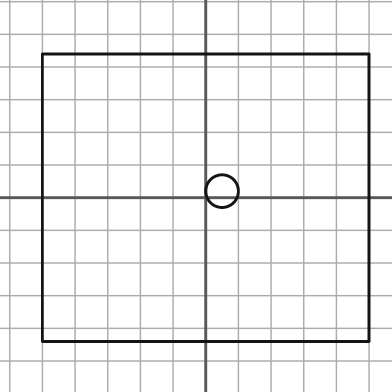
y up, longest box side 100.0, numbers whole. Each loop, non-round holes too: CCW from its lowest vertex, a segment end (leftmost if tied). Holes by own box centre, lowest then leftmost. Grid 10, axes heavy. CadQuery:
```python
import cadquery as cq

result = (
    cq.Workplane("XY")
    .moveTo(-50.0, -44.0)
    .lineTo(50.0, -44.0)
    .lineTo(50.0, 44.0)
    .lineTo(-50.0, 44.0)
    .close()
    .moveTo(5.0, 2.0)
    .circle(5.0)
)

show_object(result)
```